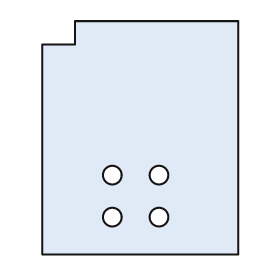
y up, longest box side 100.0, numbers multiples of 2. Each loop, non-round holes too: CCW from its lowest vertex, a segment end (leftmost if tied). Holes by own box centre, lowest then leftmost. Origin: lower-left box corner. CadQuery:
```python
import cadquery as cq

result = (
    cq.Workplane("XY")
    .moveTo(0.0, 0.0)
    .lineTo(84.0, 0.0)
    .lineTo(84.0, 100.0)
    .lineTo(14.0, 100.0)
    .lineTo(14.0, 90.0)
    .lineTo(0.0, 90.0)
    .close()
    .moveTo(30.0, 16.0)
    .circle(4.0)
    .moveTo(50.0, 16.0)
    .circle(4.0)
    .moveTo(30.0, 34.0)
    .circle(4.0)
    .moveTo(50.0, 34.0)
    .circle(4.0)
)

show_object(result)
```